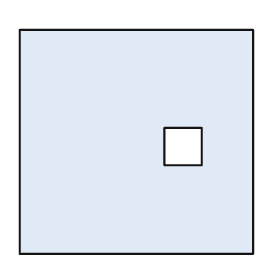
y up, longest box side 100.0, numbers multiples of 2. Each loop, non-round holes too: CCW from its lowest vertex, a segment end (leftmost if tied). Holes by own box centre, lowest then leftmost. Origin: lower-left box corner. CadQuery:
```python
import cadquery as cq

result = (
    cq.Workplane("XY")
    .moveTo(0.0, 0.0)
    .lineTo(100.0, 0.0)
    .lineTo(100.0, 96.0)
    .lineTo(0.0, 96.0)
    .close()
    .moveTo(62.0, 38.0)
    .lineTo(78.0, 38.0)
    .lineTo(78.0, 54.0)
    .lineTo(62.0, 54.0)
    .close()
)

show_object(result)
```